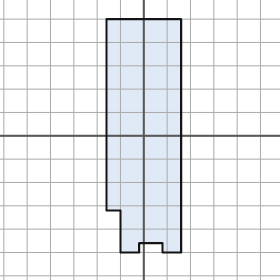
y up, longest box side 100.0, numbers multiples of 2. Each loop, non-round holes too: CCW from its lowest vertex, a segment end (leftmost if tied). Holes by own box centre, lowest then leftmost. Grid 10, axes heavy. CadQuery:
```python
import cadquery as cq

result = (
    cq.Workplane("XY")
    .moveTo(-10.0, -50.0)
    .lineTo(-2.0, -50.0)
    .lineTo(-2.0, -46.0)
    .lineTo(8.0, -46.0)
    .lineTo(8.0, -50.0)
    .lineTo(16.0, -50.0)
    .lineTo(16.0, 50.0)
    .lineTo(-16.0, 50.0)
    .lineTo(-16.0, -32.0)
    .lineTo(-10.0, -32.0)
    .close()
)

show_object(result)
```